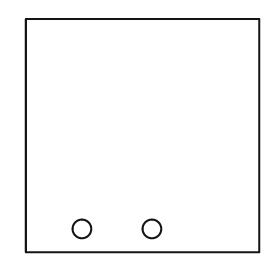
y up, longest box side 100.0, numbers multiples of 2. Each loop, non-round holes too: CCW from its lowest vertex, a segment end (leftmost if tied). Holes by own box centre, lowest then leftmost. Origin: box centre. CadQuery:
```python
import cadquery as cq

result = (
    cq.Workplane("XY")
    .moveTo(-50.0, -50.0)
    .lineTo(50.0, -50.0)
    .lineTo(50.0, 50.0)
    .lineTo(-50.0, 50.0)
    .close()
    .moveTo(-26.0, -40.0)
    .circle(4.0)
    .moveTo(4.0, -40.0)
    .circle(4.0)
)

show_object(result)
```